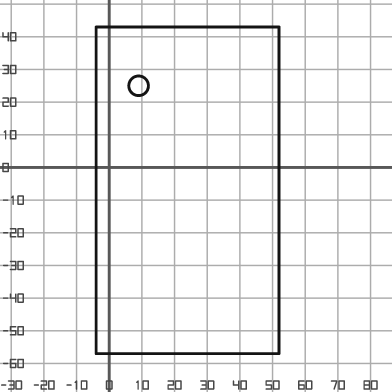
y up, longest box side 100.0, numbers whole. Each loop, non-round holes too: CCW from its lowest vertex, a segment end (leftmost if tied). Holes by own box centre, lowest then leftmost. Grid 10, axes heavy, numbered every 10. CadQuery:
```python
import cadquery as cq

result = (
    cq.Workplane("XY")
    .moveTo(-4.0, -57.0)
    .lineTo(52.0, -57.0)
    .lineTo(52.0, 43.0)
    .lineTo(-4.0, 43.0)
    .close()
    .moveTo(9.0, 25.0)
    .circle(3.0)
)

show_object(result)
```